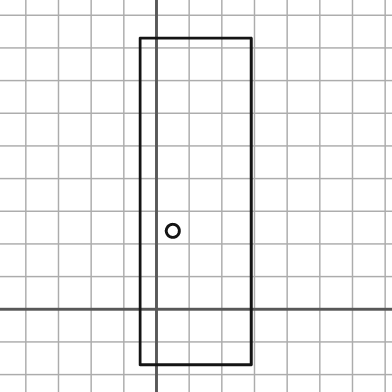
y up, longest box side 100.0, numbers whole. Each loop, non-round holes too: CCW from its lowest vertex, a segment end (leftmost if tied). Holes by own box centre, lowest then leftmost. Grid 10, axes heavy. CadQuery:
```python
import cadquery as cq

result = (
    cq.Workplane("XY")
    .moveTo(-5.0, -17.0)
    .lineTo(29.0, -17.0)
    .lineTo(29.0, 83.0)
    .lineTo(-5.0, 83.0)
    .close()
    .moveTo(5.0, 24.0)
    .circle(2.0)
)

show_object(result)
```